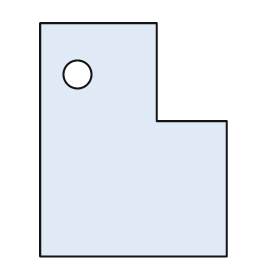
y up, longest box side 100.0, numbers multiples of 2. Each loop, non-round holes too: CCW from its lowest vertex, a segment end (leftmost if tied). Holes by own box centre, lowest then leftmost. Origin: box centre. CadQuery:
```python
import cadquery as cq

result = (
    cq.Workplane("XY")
    .moveTo(-40.0, -50.0)
    .lineTo(40.0, -50.0)
    .lineTo(40.0, 8.0)
    .lineTo(10.0, 8.0)
    .lineTo(10.0, 50.0)
    .lineTo(-40.0, 50.0)
    .close()
    .moveTo(-24.0, 28.0)
    .circle(6.0)
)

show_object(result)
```